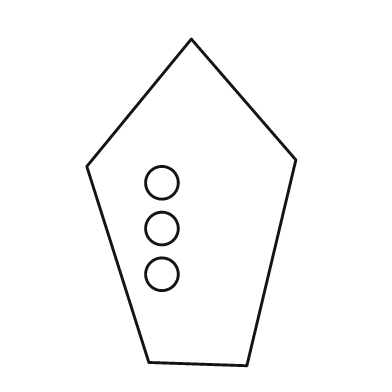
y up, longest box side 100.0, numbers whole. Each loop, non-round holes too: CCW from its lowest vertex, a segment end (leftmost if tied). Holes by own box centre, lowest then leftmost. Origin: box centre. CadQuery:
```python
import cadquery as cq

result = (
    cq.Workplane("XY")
    .moveTo(17.0, -50.0)
    .lineTo(32.0, 13.0)
    .lineTo(0.0, 50.0)
    .lineTo(-32.0, 11.0)
    .lineTo(-13.0, -49.0)
    .close()
    .moveTo(-9.0, -22.0)
    .circle(5.0)
    .moveTo(-9.0, -8.0)
    .circle(5.0)
    .moveTo(-9.0, 6.0)
    .circle(5.0)
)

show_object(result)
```